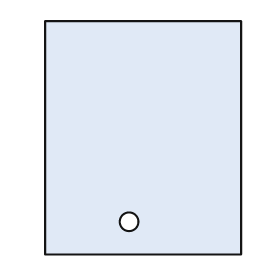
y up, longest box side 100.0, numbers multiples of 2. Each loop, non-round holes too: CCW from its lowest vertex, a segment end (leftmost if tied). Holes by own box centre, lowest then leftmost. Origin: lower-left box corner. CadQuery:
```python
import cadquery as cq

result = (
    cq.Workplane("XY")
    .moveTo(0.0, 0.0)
    .lineTo(84.0, 0.0)
    .lineTo(84.0, 100.0)
    .lineTo(0.0, 100.0)
    .close()
    .moveTo(36.0, 14.0)
    .circle(4.0)
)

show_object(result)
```